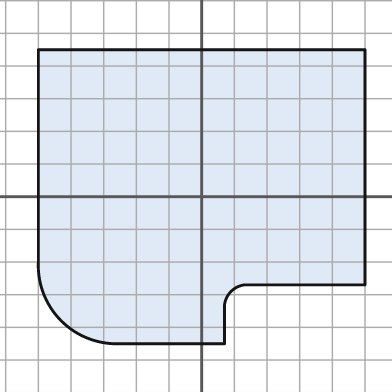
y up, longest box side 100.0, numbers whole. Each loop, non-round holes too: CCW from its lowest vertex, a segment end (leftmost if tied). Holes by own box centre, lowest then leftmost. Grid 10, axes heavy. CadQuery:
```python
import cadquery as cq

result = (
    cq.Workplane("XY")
    .moveTo(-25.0, -45.0)
    .lineTo(7.0, -45.0)
    .lineTo(7.0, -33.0)
    .threePointArc((9.0, -29.0), (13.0, -27.0))
    .lineTo(50.0, -27.0)
    .lineTo(50.0, 45.0)
    .lineTo(-50.0, 45.0)
    .lineTo(-50.0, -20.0)
    .threePointArc((-43.0, -38.0), (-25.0, -45.0))
    .close()
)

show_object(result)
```